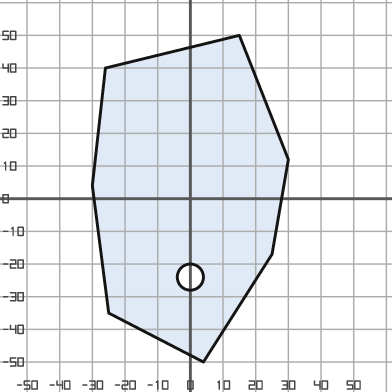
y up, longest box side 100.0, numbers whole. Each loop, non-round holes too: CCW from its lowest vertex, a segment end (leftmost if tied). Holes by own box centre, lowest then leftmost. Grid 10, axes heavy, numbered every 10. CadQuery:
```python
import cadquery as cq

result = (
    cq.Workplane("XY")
    .moveTo(4.0, -50.0)
    .lineTo(25.0, -17.0)
    .lineTo(30.0, 12.0)
    .lineTo(15.0, 50.0)
    .lineTo(-26.0, 40.0)
    .lineTo(-30.0, 4.0)
    .lineTo(-25.0, -35.0)
    .close()
    .moveTo(0.0, -24.0)
    .circle(4.0)
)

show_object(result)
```